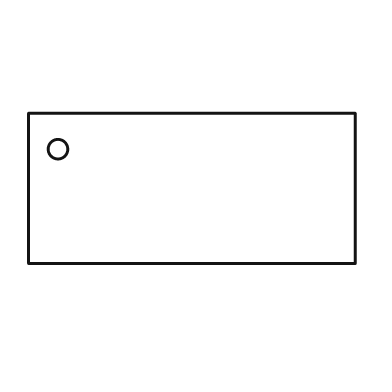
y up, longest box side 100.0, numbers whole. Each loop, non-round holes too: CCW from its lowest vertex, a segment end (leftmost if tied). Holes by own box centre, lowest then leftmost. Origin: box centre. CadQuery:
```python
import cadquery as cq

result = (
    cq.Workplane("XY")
    .moveTo(-50.0, -23.0)
    .lineTo(50.0, -23.0)
    .lineTo(50.0, 23.0)
    .lineTo(-50.0, 23.0)
    .close()
    .moveTo(-41.0, 12.0)
    .circle(3.0)
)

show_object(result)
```